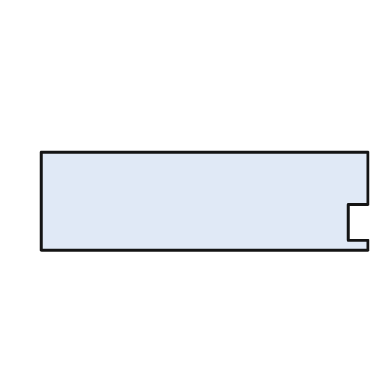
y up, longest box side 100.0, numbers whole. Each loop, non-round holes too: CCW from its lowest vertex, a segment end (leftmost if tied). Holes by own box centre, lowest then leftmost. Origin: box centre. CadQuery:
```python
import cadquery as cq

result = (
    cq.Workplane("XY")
    .moveTo(-50.0, -15.0)
    .lineTo(50.0, -15.0)
    .lineTo(50.0, -12.0)
    .lineTo(44.0, -12.0)
    .lineTo(44.0, -1.0)
    .lineTo(50.0, -1.0)
    .lineTo(50.0, 15.0)
    .lineTo(-50.0, 15.0)
    .close()
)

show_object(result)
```